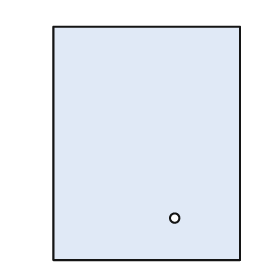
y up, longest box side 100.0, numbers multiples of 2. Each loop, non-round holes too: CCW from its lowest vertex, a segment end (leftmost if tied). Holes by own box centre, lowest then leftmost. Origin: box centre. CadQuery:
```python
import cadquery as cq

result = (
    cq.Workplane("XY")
    .moveTo(-40.0, -50.0)
    .lineTo(40.0, -50.0)
    .lineTo(40.0, 50.0)
    .lineTo(-40.0, 50.0)
    .close()
    .moveTo(12.0, -32.0)
    .circle(2.0)
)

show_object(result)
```